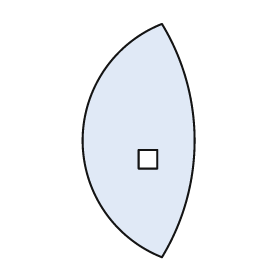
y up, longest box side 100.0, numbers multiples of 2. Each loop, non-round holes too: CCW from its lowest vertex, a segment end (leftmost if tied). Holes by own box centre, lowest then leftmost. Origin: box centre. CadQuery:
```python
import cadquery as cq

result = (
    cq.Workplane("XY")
    .moveTo(10.0, -50.0)
    .threePointArc((24.0, 0.0), (10.0, 50.0))
    .threePointArc((-24.0, 0.0), (10.0, -50.0))
    .close()
    .moveTo(0.0, -12.0)
    .lineTo(8.0, -12.0)
    .lineTo(8.0, -4.0)
    .lineTo(0.0, -4.0)
    .close()
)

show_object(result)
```